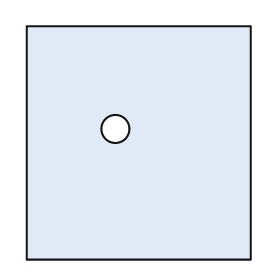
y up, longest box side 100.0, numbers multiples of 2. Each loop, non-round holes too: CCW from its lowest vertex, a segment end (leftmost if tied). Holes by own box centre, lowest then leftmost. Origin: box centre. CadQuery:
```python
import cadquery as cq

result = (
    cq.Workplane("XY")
    .moveTo(-48.0, -50.0)
    .lineTo(48.0, -50.0)
    .lineTo(48.0, 50.0)
    .lineTo(-48.0, 50.0)
    .close()
    .moveTo(-10.0, 6.0)
    .circle(6.0)
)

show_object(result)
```